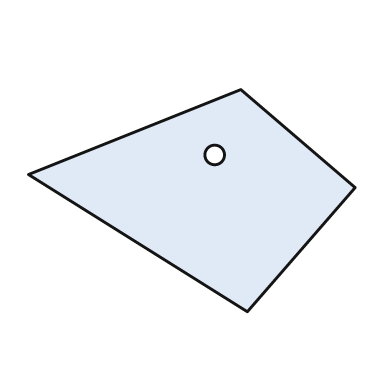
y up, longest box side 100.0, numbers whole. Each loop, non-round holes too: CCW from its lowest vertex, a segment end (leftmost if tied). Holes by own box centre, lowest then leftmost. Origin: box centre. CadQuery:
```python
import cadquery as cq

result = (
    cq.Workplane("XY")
    .moveTo(17.0, -34.0)
    .lineTo(50.0, 4.0)
    .lineTo(15.0, 34.0)
    .lineTo(-50.0, 8.0)
    .close()
    .moveTo(7.0, 14.0)
    .circle(3.0)
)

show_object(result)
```